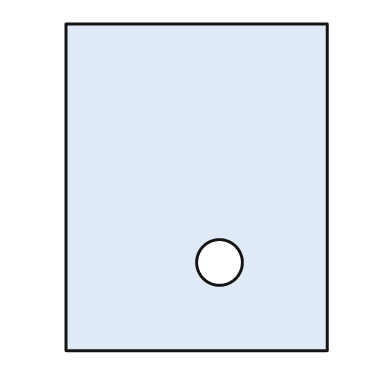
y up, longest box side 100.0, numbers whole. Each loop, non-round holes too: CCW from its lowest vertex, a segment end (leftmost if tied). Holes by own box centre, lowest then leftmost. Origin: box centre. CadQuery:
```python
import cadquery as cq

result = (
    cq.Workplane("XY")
    .moveTo(-40.0, -50.0)
    .lineTo(40.0, -50.0)
    .lineTo(40.0, 50.0)
    .lineTo(-40.0, 50.0)
    .close()
    .moveTo(7.0, -23.0)
    .circle(7.0)
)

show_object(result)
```